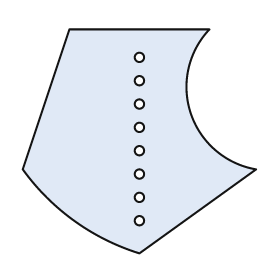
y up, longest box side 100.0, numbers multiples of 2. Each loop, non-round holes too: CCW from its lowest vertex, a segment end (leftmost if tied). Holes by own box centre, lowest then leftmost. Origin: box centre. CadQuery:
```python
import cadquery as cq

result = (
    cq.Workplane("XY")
    .moveTo(0.0, -48.0)
    .lineTo(50.0, -12.0)
    .threePointArc((22.0, 12.0), (30.0, 48.0))
    .lineTo(-30.0, 48.0)
    .lineTo(-50.0, -12.0)
    .threePointArc((-28.0, -34.0), (0.0, -48.0))
    .close()
    .moveTo(0.0, -34.0)
    .circle(2.0)
    .moveTo(0.0, -24.0)
    .circle(2.0)
    .moveTo(0.0, -14.0)
    .circle(2.0)
    .moveTo(0.0, -4.0)
    .circle(2.0)
    .moveTo(0.0, 6.0)
    .circle(2.0)
    .moveTo(0.0, 16.0)
    .circle(2.0)
    .moveTo(0.0, 26.0)
    .circle(2.0)
    .moveTo(0.0, 36.0)
    .circle(2.0)
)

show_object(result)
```